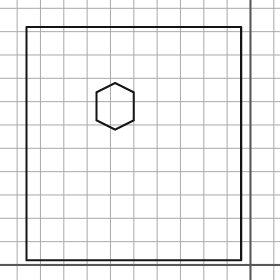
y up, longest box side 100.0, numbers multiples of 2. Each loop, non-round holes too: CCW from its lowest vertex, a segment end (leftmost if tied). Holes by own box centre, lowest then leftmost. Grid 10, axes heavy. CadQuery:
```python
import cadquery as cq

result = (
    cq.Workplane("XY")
    .moveTo(-96.0, 2.0)
    .lineTo(-4.0, 2.0)
    .lineTo(-4.0, 102.0)
    .lineTo(-96.0, 102.0)
    .close()
    .moveTo(-58.0, 58.0)
    .lineTo(-50.0, 62.0)
    .lineTo(-50.0, 74.0)
    .lineTo(-58.0, 78.0)
    .lineTo(-66.0, 74.0)
    .lineTo(-66.0, 62.0)
    .close()
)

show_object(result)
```